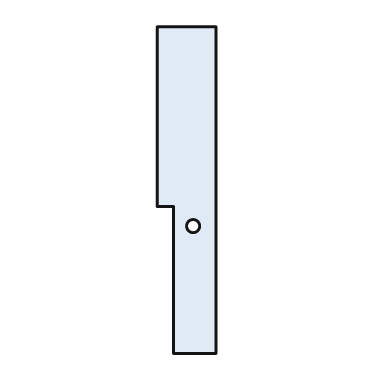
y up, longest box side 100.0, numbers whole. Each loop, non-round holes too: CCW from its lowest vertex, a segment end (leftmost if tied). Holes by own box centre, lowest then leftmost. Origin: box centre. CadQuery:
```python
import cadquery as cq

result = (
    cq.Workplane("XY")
    .moveTo(-4.0, -50.0)
    .lineTo(9.0, -50.0)
    .lineTo(9.0, 50.0)
    .lineTo(-9.0, 50.0)
    .lineTo(-9.0, -5.0)
    .lineTo(-4.0, -5.0)
    .close()
    .moveTo(2.0, -11.0)
    .circle(2.0)
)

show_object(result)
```